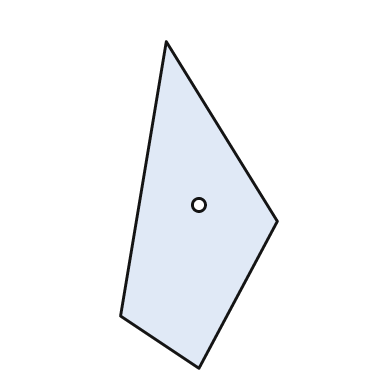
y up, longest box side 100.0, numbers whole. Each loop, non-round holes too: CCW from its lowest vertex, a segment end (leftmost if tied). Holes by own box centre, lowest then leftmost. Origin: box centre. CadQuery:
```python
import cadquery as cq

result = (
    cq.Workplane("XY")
    .moveTo(0.0, -50.0)
    .lineTo(24.0, -5.0)
    .lineTo(-10.0, 50.0)
    .lineTo(-24.0, -34.0)
    .close()
    .moveTo(0.0, 0.0)
    .circle(2.0)
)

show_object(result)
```